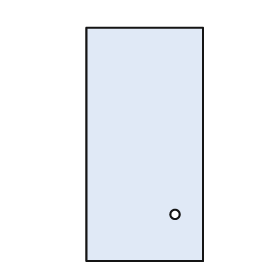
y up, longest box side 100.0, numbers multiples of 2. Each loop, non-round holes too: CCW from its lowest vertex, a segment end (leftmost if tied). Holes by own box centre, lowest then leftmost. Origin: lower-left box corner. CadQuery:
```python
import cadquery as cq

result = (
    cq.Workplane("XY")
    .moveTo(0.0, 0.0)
    .lineTo(50.0, 0.0)
    .lineTo(50.0, 100.0)
    .lineTo(0.0, 100.0)
    .close()
    .moveTo(38.0, 20.0)
    .circle(2.0)
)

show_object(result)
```